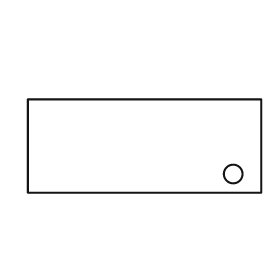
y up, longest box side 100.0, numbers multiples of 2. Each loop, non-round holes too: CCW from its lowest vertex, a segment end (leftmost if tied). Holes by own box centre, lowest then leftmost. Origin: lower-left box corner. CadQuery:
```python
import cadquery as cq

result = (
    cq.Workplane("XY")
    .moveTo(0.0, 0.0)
    .lineTo(100.0, 0.0)
    .lineTo(100.0, 40.0)
    .lineTo(0.0, 40.0)
    .close()
    .moveTo(88.0, 8.0)
    .circle(4.0)
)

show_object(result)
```